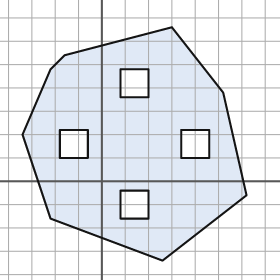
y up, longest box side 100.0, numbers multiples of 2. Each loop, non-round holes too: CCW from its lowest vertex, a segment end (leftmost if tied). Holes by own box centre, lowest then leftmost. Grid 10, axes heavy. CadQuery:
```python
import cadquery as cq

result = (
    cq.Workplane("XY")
    .moveTo(26.0, -34.0)
    .lineTo(62.0, -6.0)
    .lineTo(52.0, 38.0)
    .lineTo(30.0, 66.0)
    .lineTo(-16.0, 54.0)
    .lineTo(-22.0, 48.0)
    .lineTo(-34.0, 20.0)
    .lineTo(-22.0, -16.0)
    .close()
    .moveTo(8.0, -16.0)
    .lineTo(20.0, -16.0)
    .lineTo(20.0, -4.0)
    .lineTo(8.0, -4.0)
    .close()
    .moveTo(-18.0, 10.0)
    .lineTo(-6.0, 10.0)
    .lineTo(-6.0, 22.0)
    .lineTo(-18.0, 22.0)
    .close()
    .moveTo(34.0, 10.0)
    .lineTo(46.0, 10.0)
    .lineTo(46.0, 22.0)
    .lineTo(34.0, 22.0)
    .close()
    .moveTo(8.0, 36.0)
    .lineTo(20.0, 36.0)
    .lineTo(20.0, 48.0)
    .lineTo(8.0, 48.0)
    .close()
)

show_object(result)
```